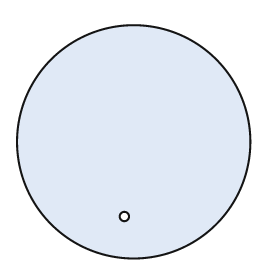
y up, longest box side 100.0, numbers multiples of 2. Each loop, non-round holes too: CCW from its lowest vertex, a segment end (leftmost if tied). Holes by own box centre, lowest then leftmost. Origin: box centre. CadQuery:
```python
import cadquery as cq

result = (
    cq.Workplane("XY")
    .moveTo(0.0, 0.0)
    .circle(50.0)
    .moveTo(-4.0, -32.0)
    .circle(2.0)
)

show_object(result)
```